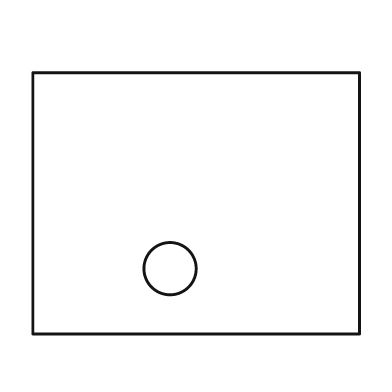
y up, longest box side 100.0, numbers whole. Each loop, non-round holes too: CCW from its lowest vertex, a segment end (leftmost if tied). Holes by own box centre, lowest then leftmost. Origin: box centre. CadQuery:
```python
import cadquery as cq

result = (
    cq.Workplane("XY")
    .moveTo(-50.0, -40.0)
    .lineTo(50.0, -40.0)
    .lineTo(50.0, 40.0)
    .lineTo(-50.0, 40.0)
    .close()
    .moveTo(-8.0, -20.0)
    .circle(8.0)
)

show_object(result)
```